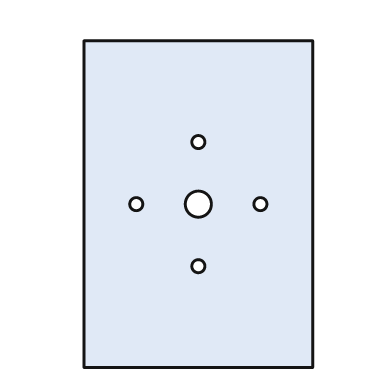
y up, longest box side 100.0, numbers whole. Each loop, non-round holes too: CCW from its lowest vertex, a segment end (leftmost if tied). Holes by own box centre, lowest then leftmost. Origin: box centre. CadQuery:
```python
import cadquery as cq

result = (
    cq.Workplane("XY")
    .moveTo(-35.0, -50.0)
    .lineTo(35.0, -50.0)
    .lineTo(35.0, 50.0)
    .lineTo(-35.0, 50.0)
    .close()
    .moveTo(0.0, -19.0)
    .circle(2.0)
    .moveTo(-19.0, 0.0)
    .circle(2.0)
    .moveTo(0.0, 0.0)
    .circle(4.0)
    .moveTo(19.0, 0.0)
    .circle(2.0)
    .moveTo(0.0, 19.0)
    .circle(2.0)
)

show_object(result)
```